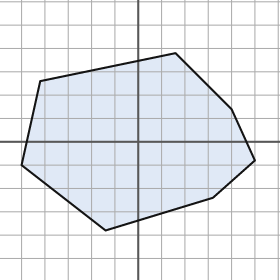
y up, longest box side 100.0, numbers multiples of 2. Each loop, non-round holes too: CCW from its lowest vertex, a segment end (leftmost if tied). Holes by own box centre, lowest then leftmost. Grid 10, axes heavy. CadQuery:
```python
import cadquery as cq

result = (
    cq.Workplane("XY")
    .moveTo(-14.0, -38.0)
    .lineTo(32.0, -24.0)
    .lineTo(50.0, -8.0)
    .lineTo(40.0, 14.0)
    .lineTo(16.0, 38.0)
    .lineTo(-42.0, 26.0)
    .lineTo(-50.0, -10.0)
    .close()
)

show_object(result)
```